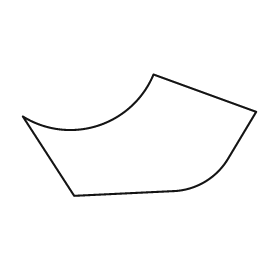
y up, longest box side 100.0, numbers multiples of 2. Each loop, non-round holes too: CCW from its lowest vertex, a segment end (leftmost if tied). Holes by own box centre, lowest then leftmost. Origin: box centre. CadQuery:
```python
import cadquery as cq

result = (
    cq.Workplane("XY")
    .moveTo(-28.0, -26.0)
    .lineTo(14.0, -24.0)
    .threePointArc((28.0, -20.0), (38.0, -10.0))
    .lineTo(50.0, 10.0)
    .lineTo(6.0, 26.0)
    .threePointArc((-18.0, 4.0), (-50.0, 8.0))
    .close()
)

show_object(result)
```